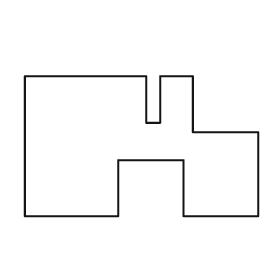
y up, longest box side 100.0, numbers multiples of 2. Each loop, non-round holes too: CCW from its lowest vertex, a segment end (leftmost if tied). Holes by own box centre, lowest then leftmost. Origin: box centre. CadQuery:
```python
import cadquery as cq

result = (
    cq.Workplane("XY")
    .moveTo(-50.0, -30.0)
    .lineTo(-10.0, -30.0)
    .lineTo(-10.0, -6.0)
    .lineTo(18.0, -6.0)
    .lineTo(18.0, -30.0)
    .lineTo(50.0, -30.0)
    .lineTo(50.0, 6.0)
    .lineTo(22.0, 6.0)
    .lineTo(22.0, 30.0)
    .lineTo(8.0, 30.0)
    .lineTo(8.0, 10.0)
    .lineTo(2.0, 10.0)
    .lineTo(2.0, 30.0)
    .lineTo(-50.0, 30.0)
    .close()
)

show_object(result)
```